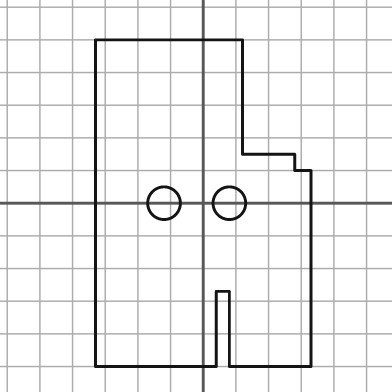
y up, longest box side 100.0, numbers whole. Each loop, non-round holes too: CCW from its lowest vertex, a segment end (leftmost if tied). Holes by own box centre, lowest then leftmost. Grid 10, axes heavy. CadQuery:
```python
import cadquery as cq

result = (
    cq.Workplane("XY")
    .moveTo(-33.0, -50.0)
    .lineTo(4.0, -50.0)
    .lineTo(4.0, -27.0)
    .lineTo(8.0, -27.0)
    .lineTo(8.0, -50.0)
    .lineTo(33.0, -50.0)
    .lineTo(33.0, 10.0)
    .lineTo(28.0, 10.0)
    .lineTo(28.0, 15.0)
    .lineTo(12.0, 15.0)
    .lineTo(12.0, 50.0)
    .lineTo(-33.0, 50.0)
    .close()
    .moveTo(-12.0, 0.0)
    .circle(5.0)
    .moveTo(8.0, 0.0)
    .circle(5.0)
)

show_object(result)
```